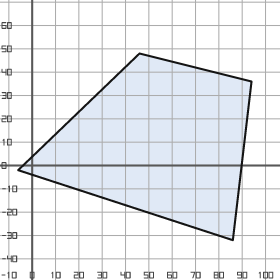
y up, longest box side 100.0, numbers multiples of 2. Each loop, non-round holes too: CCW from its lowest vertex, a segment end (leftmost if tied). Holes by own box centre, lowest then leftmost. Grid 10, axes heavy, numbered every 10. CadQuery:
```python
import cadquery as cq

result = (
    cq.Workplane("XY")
    .moveTo(86.0, -32.0)
    .lineTo(94.0, 36.0)
    .lineTo(46.0, 48.0)
    .lineTo(-6.0, -2.0)
    .close()
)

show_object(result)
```